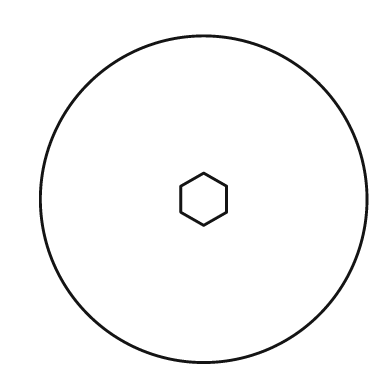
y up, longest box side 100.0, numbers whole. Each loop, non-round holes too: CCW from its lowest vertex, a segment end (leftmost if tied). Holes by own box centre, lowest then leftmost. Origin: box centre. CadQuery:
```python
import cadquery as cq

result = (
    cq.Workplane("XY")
    .moveTo(0.0, 0.0)
    .circle(50.0)
    .moveTo(0.0, -8.0)
    .lineTo(7.0, -4.0)
    .lineTo(7.0, 4.0)
    .lineTo(0.0, 8.0)
    .lineTo(-7.0, 4.0)
    .lineTo(-7.0, -4.0)
    .close()
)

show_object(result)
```